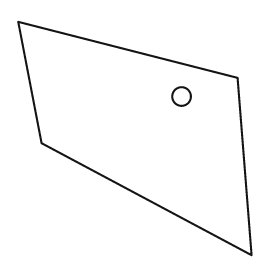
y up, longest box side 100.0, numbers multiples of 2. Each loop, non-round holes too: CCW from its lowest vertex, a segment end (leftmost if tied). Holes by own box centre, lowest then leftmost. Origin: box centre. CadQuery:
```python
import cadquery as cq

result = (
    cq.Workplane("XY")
    .moveTo(50.0, -50.0)
    .lineTo(44.0, 26.0)
    .lineTo(-50.0, 50.0)
    .lineTo(-40.0, -2.0)
    .close()
    .moveTo(20.0, 18.0)
    .circle(4.0)
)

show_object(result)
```